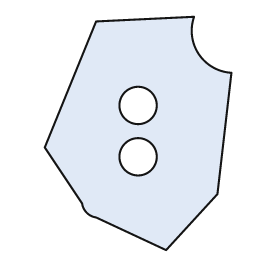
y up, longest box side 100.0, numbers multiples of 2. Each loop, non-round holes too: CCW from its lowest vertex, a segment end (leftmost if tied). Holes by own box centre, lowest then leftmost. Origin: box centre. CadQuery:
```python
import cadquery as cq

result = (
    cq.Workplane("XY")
    .moveTo(12.0, -50.0)
    .lineTo(34.0, -26.0)
    .lineTo(40.0, 26.0)
    .threePointArc((26.0, 34.0), (24.0, 50.0))
    .lineTo(-18.0, 48.0)
    .lineTo(-40.0, -6.0)
    .lineTo(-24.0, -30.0)
    .threePointArc((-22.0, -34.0), (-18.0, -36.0))
    .close()
    .moveTo(0.0, -10.0)
    .circle(8.0)
    .moveTo(0.0, 12.0)
    .circle(8.0)
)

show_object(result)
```